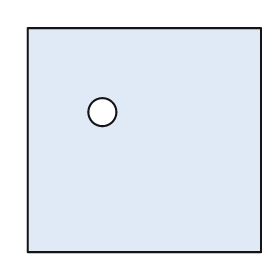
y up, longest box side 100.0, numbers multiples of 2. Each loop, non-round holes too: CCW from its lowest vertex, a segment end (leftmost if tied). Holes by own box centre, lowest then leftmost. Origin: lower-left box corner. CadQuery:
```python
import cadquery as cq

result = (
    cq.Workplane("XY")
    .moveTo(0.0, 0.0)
    .lineTo(100.0, 0.0)
    .lineTo(100.0, 96.0)
    .lineTo(0.0, 96.0)
    .close()
    .moveTo(32.0, 60.0)
    .circle(6.0)
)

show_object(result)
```